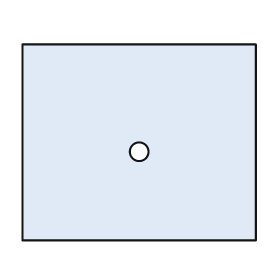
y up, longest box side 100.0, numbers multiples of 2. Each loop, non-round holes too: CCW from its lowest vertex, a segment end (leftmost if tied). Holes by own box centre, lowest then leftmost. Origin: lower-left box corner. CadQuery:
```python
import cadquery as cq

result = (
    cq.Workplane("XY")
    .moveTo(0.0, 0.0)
    .lineTo(100.0, 0.0)
    .lineTo(100.0, 84.0)
    .lineTo(0.0, 84.0)
    .close()
    .moveTo(50.0, 38.0)
    .circle(4.0)
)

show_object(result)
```